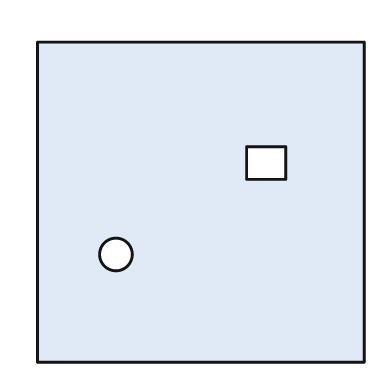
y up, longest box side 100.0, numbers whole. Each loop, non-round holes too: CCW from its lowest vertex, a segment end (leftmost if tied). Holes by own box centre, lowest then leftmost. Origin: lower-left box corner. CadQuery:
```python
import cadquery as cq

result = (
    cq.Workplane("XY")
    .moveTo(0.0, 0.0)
    .lineTo(100.0, 0.0)
    .lineTo(100.0, 98.0)
    .lineTo(0.0, 98.0)
    .close()
    .moveTo(24.0, 33.0)
    .circle(5.0)
    .moveTo(64.0, 56.0)
    .lineTo(76.0, 56.0)
    .lineTo(76.0, 66.0)
    .lineTo(64.0, 66.0)
    .close()
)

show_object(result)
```